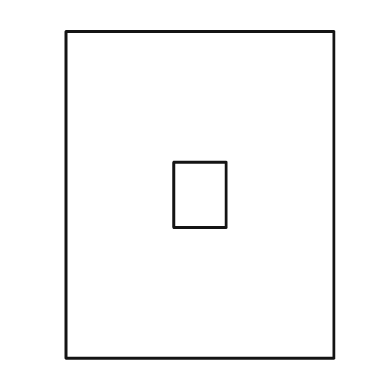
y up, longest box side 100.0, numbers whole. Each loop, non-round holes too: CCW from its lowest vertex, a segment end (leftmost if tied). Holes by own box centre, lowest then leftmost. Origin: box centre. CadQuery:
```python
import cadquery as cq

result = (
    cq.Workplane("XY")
    .moveTo(-41.0, -50.0)
    .lineTo(41.0, -50.0)
    .lineTo(41.0, 50.0)
    .lineTo(-41.0, 50.0)
    .close()
    .moveTo(-8.0, -10.0)
    .lineTo(8.0, -10.0)
    .lineTo(8.0, 10.0)
    .lineTo(-8.0, 10.0)
    .close()
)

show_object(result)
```